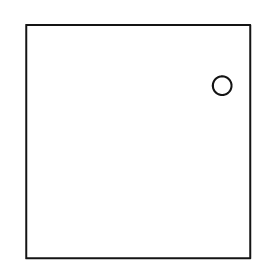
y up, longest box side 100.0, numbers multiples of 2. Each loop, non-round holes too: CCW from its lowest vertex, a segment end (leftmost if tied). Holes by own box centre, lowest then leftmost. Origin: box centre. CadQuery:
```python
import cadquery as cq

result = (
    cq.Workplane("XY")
    .moveTo(-48.0, -50.0)
    .lineTo(48.0, -50.0)
    .lineTo(48.0, 50.0)
    .lineTo(-48.0, 50.0)
    .close()
    .moveTo(36.0, 24.0)
    .circle(4.0)
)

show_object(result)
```